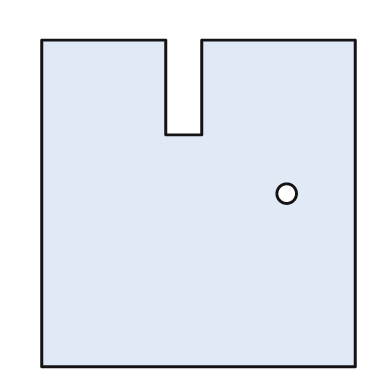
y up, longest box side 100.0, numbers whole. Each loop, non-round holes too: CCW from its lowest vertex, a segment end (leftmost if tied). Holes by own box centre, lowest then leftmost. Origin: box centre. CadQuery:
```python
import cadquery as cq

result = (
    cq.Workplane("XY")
    .moveTo(-48.0, -50.0)
    .lineTo(48.0, -50.0)
    .lineTo(48.0, 50.0)
    .lineTo(1.0, 50.0)
    .lineTo(1.0, 21.0)
    .lineTo(-10.0, 21.0)
    .lineTo(-10.0, 50.0)
    .lineTo(-48.0, 50.0)
    .close()
    .moveTo(27.0, 3.0)
    .circle(3.0)
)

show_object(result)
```